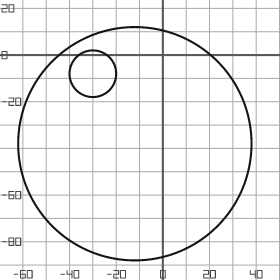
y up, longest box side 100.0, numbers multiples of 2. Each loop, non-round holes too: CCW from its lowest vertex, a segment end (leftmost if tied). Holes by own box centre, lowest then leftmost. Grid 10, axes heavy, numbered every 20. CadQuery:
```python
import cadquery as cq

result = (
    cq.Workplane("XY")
    .moveTo(-12.0, -38.0)
    .circle(50.0)
    .moveTo(-30.0, -8.0)
    .circle(10.0)
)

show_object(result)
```